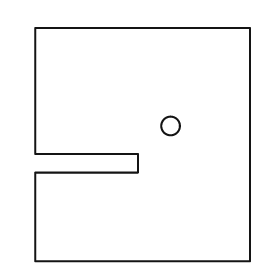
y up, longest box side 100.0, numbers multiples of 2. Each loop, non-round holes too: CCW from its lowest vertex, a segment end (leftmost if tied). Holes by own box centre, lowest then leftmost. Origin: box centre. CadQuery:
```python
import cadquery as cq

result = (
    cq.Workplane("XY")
    .moveTo(-46.0, -50.0)
    .lineTo(46.0, -50.0)
    .lineTo(46.0, 50.0)
    .lineTo(-46.0, 50.0)
    .lineTo(-46.0, -4.0)
    .lineTo(-2.0, -4.0)
    .lineTo(-2.0, -12.0)
    .lineTo(-46.0, -12.0)
    .close()
    .moveTo(12.0, 8.0)
    .circle(4.0)
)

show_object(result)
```